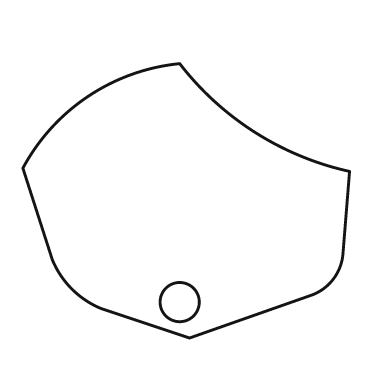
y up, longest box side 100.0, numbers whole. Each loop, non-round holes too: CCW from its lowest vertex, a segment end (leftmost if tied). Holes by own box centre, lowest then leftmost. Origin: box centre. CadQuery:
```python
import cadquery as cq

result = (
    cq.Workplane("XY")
    .moveTo(1.0, -42.0)
    .lineTo(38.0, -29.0)
    .threePointArc((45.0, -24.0), (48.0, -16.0))
    .lineTo(50.0, 9.0)
    .threePointArc((21.0, 21.0), (-2.0, 42.0))
    .threePointArc((-30.0, 32.0), (-50.0, 10.0))
    .lineTo(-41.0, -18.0)
    .threePointArc((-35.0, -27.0), (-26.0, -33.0))
    .close()
    .moveTo(-2.0, -31.0)
    .circle(6.0)
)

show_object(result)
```